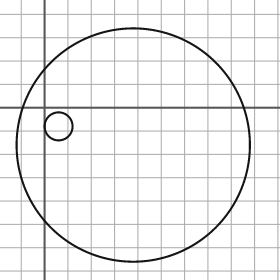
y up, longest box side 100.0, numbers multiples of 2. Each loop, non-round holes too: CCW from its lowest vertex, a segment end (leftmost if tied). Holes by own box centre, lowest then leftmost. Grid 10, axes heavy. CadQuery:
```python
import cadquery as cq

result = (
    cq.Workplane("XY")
    .moveTo(38.0, -16.0)
    .circle(50.0)
    .moveTo(6.0, -8.0)
    .circle(6.0)
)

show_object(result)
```